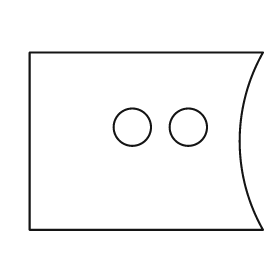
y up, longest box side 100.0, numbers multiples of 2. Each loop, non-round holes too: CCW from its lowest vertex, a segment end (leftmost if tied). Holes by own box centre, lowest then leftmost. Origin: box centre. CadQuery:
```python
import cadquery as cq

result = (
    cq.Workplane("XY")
    .moveTo(-50.0, -38.0)
    .lineTo(50.0, -38.0)
    .threePointArc((40.0, 0.0), (50.0, 38.0))
    .lineTo(-50.0, 38.0)
    .close()
    .moveTo(-6.0, 6.0)
    .circle(8.0)
    .moveTo(18.0, 6.0)
    .circle(8.0)
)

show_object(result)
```